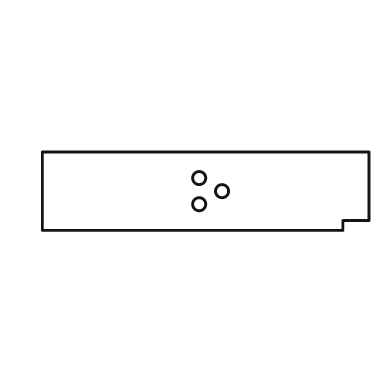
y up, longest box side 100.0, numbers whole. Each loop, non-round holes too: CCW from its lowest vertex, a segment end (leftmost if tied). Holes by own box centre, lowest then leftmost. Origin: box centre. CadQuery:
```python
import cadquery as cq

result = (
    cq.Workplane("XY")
    .moveTo(-50.0, -12.0)
    .lineTo(42.0, -12.0)
    .lineTo(42.0, -9.0)
    .lineTo(50.0, -9.0)
    .lineTo(50.0, 12.0)
    .lineTo(-50.0, 12.0)
    .close()
    .moveTo(-2.0, -4.0)
    .circle(2.0)
    .moveTo(5.0, 0.0)
    .circle(2.0)
    .moveTo(-2.0, 4.0)
    .circle(2.0)
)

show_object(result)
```